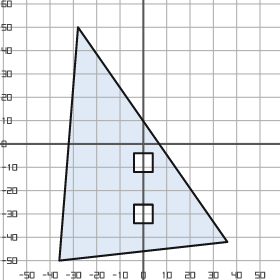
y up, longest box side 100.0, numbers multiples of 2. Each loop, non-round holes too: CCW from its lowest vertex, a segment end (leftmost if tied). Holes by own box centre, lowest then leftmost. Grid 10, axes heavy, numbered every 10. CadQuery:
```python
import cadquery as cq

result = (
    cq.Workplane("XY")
    .moveTo(-36.0, -50.0)
    .lineTo(36.0, -42.0)
    .lineTo(-28.0, 50.0)
    .close()
    .moveTo(-4.0, -34.0)
    .lineTo(4.0, -34.0)
    .lineTo(4.0, -26.0)
    .lineTo(-4.0, -26.0)
    .close()
    .moveTo(-4.0, -12.0)
    .lineTo(4.0, -12.0)
    .lineTo(4.0, -4.0)
    .lineTo(-4.0, -4.0)
    .close()
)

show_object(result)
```